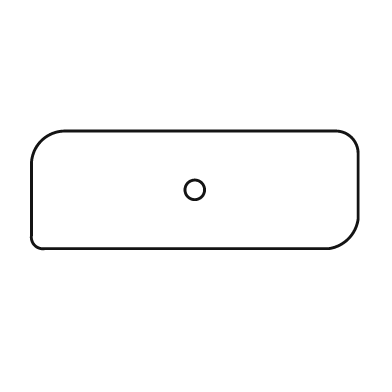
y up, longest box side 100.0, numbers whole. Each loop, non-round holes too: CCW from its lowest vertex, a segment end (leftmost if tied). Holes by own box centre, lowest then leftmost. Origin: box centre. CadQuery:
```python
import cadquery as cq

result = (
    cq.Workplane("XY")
    .moveTo(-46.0, -18.0)
    .lineTo(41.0, -18.0)
    .threePointArc((47.0, -15.0), (50.0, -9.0))
    .lineTo(50.0, 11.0)
    .threePointArc((48.0, 16.0), (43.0, 18.0))
    .lineTo(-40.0, 18.0)
    .threePointArc((-47.0, 15.0), (-50.0, 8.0))
    .lineTo(-50.0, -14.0)
    .threePointArc((-49.0, -17.0), (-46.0, -18.0))
    .close()
    .moveTo(0.0, 0.0)
    .circle(3.0)
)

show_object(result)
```